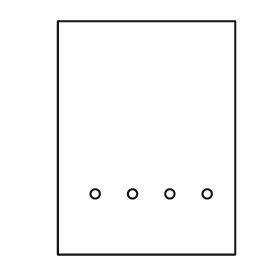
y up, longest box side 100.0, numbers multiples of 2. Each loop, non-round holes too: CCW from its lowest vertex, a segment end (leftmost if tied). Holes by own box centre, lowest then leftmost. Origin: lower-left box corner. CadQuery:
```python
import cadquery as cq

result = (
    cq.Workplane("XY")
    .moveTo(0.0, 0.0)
    .lineTo(76.0, 0.0)
    .lineTo(76.0, 100.0)
    .lineTo(0.0, 100.0)
    .close()
    .moveTo(16.0, 26.0)
    .circle(2.0)
    .moveTo(32.0, 26.0)
    .circle(2.0)
    .moveTo(48.0, 26.0)
    .circle(2.0)
    .moveTo(64.0, 26.0)
    .circle(2.0)
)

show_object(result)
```